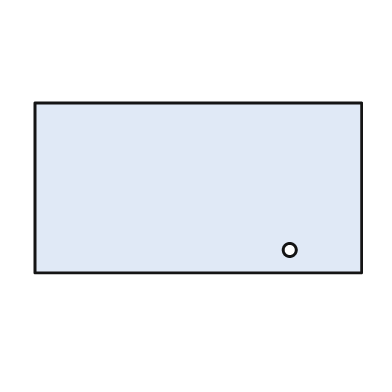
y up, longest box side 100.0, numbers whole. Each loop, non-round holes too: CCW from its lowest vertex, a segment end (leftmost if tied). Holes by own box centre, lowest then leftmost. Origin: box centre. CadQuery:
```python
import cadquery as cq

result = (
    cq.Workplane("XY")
    .moveTo(-50.0, -26.0)
    .lineTo(50.0, -26.0)
    .lineTo(50.0, 26.0)
    .lineTo(-50.0, 26.0)
    .close()
    .moveTo(28.0, -19.0)
    .circle(2.0)
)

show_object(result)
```